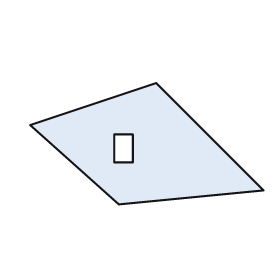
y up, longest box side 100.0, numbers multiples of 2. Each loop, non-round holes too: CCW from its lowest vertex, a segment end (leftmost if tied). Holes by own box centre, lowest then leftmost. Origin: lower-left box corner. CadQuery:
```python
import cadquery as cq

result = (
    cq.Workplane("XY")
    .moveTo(38.0, 0.0)
    .lineTo(100.0, 6.0)
    .lineTo(54.0, 52.0)
    .lineTo(0.0, 34.0)
    .close()
    .moveTo(36.0, 18.0)
    .lineTo(44.0, 18.0)
    .lineTo(44.0, 30.0)
    .lineTo(36.0, 30.0)
    .close()
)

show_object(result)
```